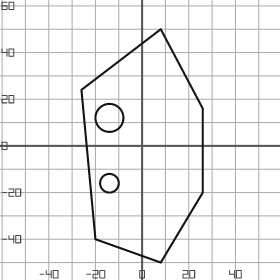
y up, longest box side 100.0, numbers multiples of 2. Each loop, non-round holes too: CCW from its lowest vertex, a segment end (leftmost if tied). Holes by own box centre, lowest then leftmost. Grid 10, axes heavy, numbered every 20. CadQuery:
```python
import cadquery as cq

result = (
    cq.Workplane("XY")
    .moveTo(8.0, -50.0)
    .lineTo(26.0, -20.0)
    .lineTo(26.0, 16.0)
    .lineTo(8.0, 50.0)
    .lineTo(-26.0, 24.0)
    .lineTo(-20.0, -40.0)
    .close()
    .moveTo(-14.0, -16.0)
    .circle(4.0)
    .moveTo(-14.0, 12.0)
    .circle(6.0)
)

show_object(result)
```